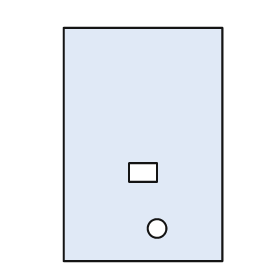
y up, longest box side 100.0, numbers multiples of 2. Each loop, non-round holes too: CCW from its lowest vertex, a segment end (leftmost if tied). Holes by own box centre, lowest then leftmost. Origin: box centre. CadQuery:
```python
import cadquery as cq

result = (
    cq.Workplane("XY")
    .moveTo(-34.0, -50.0)
    .lineTo(34.0, -50.0)
    .lineTo(34.0, 50.0)
    .lineTo(-34.0, 50.0)
    .close()
    .moveTo(6.0, -36.0)
    .circle(4.0)
    .moveTo(-6.0, -16.0)
    .lineTo(6.0, -16.0)
    .lineTo(6.0, -8.0)
    .lineTo(-6.0, -8.0)
    .close()
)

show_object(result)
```